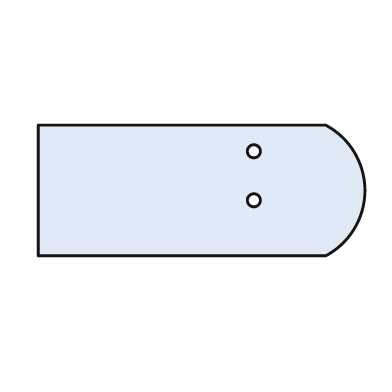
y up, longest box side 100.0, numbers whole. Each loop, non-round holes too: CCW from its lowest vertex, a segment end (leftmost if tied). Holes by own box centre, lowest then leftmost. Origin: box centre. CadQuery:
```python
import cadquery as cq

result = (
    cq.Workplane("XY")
    .moveTo(-50.0, -20.0)
    .lineTo(38.0, -20.0)
    .threePointArc((50.0, 0.0), (38.0, 20.0))
    .lineTo(-50.0, 20.0)
    .close()
    .moveTo(16.0, -3.0)
    .circle(2.0)
    .moveTo(16.0, 12.0)
    .circle(2.0)
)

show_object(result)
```